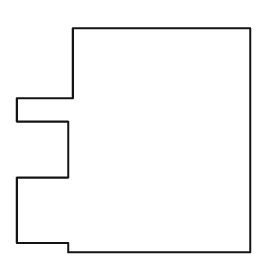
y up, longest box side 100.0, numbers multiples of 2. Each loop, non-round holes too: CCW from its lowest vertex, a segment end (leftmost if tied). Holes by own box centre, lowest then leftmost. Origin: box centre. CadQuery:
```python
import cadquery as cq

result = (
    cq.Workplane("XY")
    .moveTo(-28.0, -48.0)
    .lineTo(50.0, -48.0)
    .lineTo(50.0, 48.0)
    .lineTo(-26.0, 48.0)
    .lineTo(-26.0, 18.0)
    .lineTo(-50.0, 18.0)
    .lineTo(-50.0, 8.0)
    .lineTo(-28.0, 8.0)
    .lineTo(-28.0, -16.0)
    .lineTo(-50.0, -16.0)
    .lineTo(-50.0, -44.0)
    .lineTo(-28.0, -44.0)
    .close()
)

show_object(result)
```